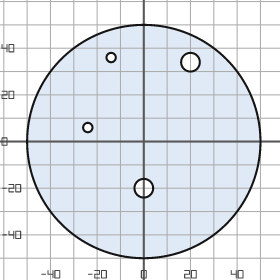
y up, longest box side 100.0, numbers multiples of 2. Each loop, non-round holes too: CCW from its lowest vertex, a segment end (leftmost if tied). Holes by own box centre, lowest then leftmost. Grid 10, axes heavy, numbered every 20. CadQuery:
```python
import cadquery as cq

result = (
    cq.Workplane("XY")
    .moveTo(0.0, 0.0)
    .circle(50.0)
    .moveTo(0.0, -20.0)
    .circle(4.0)
    .moveTo(-24.0, 6.0)
    .circle(2.0)
    .moveTo(20.0, 34.0)
    .circle(4.0)
    .moveTo(-14.0, 36.0)
    .circle(2.0)
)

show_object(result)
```